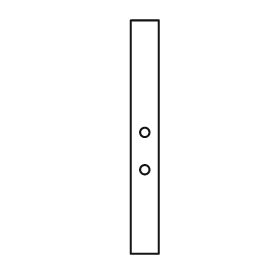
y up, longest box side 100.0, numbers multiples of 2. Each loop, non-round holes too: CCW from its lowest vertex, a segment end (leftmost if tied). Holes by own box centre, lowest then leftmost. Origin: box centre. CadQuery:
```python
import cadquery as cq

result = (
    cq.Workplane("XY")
    .moveTo(-6.0, -50.0)
    .lineTo(6.0, -50.0)
    .lineTo(6.0, 50.0)
    .lineTo(-6.0, 50.0)
    .close()
    .moveTo(0.0, -14.0)
    .circle(2.0)
    .moveTo(0.0, 2.0)
    .circle(2.0)
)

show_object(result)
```